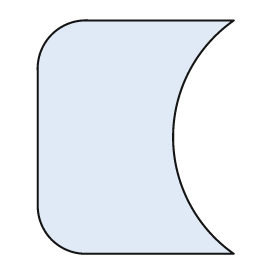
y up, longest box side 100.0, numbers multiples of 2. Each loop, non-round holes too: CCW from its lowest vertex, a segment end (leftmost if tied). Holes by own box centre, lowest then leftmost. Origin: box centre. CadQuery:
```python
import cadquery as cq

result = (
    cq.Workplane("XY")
    .moveTo(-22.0, -50.0)
    .lineTo(42.0, -50.0)
    .threePointArc((16.0, 0.0), (42.0, 50.0))
    .lineTo(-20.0, 50.0)
    .threePointArc((-36.0, 44.0), (-42.0, 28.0))
    .lineTo(-42.0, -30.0)
    .threePointArc((-36.0, -44.0), (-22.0, -50.0))
    .close()
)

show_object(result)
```